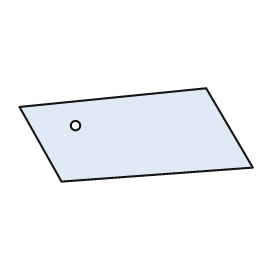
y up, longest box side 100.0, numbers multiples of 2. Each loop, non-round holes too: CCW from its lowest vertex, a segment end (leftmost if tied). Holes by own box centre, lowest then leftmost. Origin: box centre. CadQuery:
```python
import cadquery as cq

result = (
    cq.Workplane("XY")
    .moveTo(-32.0, -20.0)
    .lineTo(50.0, -14.0)
    .lineTo(30.0, 20.0)
    .lineTo(-50.0, 12.0)
    .close()
    .moveTo(-26.0, 4.0)
    .circle(2.0)
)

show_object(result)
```